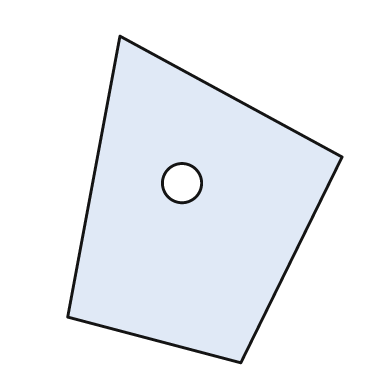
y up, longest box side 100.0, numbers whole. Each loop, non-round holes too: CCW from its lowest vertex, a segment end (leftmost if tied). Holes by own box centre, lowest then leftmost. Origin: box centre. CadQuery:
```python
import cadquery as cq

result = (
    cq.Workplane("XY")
    .moveTo(11.0, -50.0)
    .lineTo(42.0, 13.0)
    .lineTo(-26.0, 50.0)
    .lineTo(-42.0, -36.0)
    .close()
    .moveTo(-7.0, 5.0)
    .circle(6.0)
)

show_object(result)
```